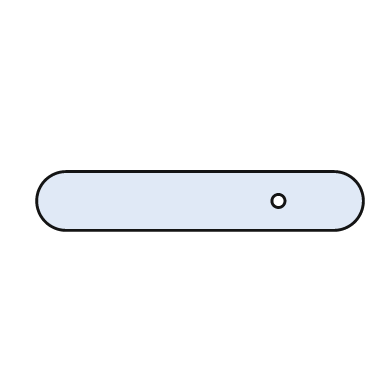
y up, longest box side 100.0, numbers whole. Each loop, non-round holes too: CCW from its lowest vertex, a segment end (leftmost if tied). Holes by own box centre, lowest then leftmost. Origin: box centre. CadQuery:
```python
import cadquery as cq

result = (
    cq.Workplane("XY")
    .moveTo(-41.0, -9.0)
    .lineTo(41.0, -9.0)
    .threePointArc((50.0, 0.0), (41.0, 9.0))
    .lineTo(-41.0, 9.0)
    .threePointArc((-50.0, 0.0), (-41.0, -9.0))
    .close()
    .moveTo(24.0, 0.0)
    .circle(2.0)
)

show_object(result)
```